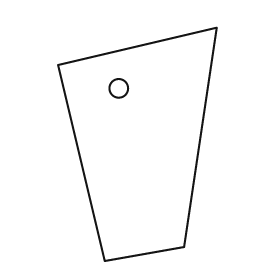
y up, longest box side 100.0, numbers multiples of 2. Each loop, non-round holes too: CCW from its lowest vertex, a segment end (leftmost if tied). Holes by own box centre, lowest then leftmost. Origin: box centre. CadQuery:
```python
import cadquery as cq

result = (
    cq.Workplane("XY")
    .moveTo(-14.0, -50.0)
    .lineTo(20.0, -44.0)
    .lineTo(34.0, 50.0)
    .lineTo(-34.0, 34.0)
    .close()
    .moveTo(-8.0, 24.0)
    .circle(4.0)
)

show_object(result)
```